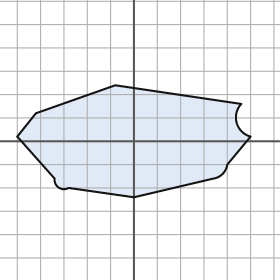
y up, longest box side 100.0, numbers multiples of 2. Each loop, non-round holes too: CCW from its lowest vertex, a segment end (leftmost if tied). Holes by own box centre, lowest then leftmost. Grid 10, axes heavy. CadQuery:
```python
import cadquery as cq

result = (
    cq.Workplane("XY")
    .moveTo(0.0, -24.0)
    .lineTo(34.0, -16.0)
    .threePointArc((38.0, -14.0), (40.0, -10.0))
    .lineTo(50.0, 2.0)
    .threePointArc((44.0, 8.0), (46.0, 16.0))
    .lineTo(-8.0, 24.0)
    .lineTo(-42.0, 12.0)
    .lineTo(-50.0, 2.0)
    .lineTo(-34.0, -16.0)
    .threePointArc((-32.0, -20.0), (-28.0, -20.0))
    .close()
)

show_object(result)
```